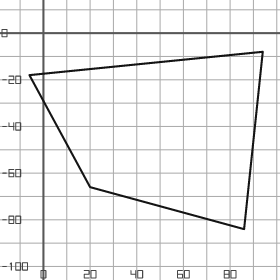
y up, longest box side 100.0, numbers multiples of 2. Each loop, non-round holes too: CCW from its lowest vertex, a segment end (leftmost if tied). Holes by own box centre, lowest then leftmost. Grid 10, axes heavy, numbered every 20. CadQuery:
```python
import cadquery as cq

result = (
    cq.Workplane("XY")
    .moveTo(86.0, -84.0)
    .lineTo(94.0, -8.0)
    .lineTo(-6.0, -18.0)
    .lineTo(20.0, -66.0)
    .close()
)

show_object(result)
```